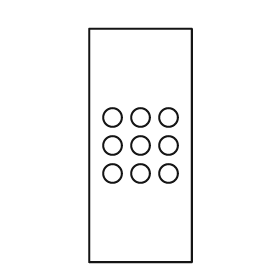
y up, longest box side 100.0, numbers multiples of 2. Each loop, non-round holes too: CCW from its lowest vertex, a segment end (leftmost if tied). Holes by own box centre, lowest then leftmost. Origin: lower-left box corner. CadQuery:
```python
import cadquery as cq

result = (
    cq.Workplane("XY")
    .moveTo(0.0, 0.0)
    .lineTo(44.0, 0.0)
    .lineTo(44.0, 100.0)
    .lineTo(0.0, 100.0)
    .close()
    .moveTo(10.0, 38.0)
    .circle(4.0)
    .moveTo(22.0, 38.0)
    .circle(4.0)
    .moveTo(34.0, 38.0)
    .circle(4.0)
    .moveTo(10.0, 50.0)
    .circle(4.0)
    .moveTo(22.0, 50.0)
    .circle(4.0)
    .moveTo(34.0, 50.0)
    .circle(4.0)
    .moveTo(10.0, 62.0)
    .circle(4.0)
    .moveTo(22.0, 62.0)
    .circle(4.0)
    .moveTo(34.0, 62.0)
    .circle(4.0)
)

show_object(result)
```